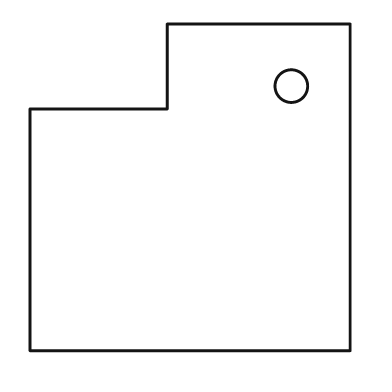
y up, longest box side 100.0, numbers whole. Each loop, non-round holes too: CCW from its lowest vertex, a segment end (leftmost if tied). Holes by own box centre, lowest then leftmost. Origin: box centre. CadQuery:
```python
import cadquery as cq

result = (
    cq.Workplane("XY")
    .moveTo(-49.0, -50.0)
    .lineTo(49.0, -50.0)
    .lineTo(49.0, 50.0)
    .lineTo(-7.0, 50.0)
    .lineTo(-7.0, 24.0)
    .lineTo(-49.0, 24.0)
    .close()
    .moveTo(31.0, 31.0)
    .circle(5.0)
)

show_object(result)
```